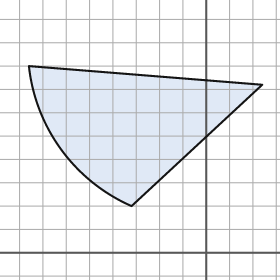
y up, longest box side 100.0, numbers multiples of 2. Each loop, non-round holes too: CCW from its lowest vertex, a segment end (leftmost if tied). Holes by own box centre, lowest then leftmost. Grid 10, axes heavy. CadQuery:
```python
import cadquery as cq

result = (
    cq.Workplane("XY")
    .moveTo(-32.0, 20.0)
    .lineTo(24.0, 72.0)
    .lineTo(-76.0, 80.0)
    .threePointArc((-62.0, 44.0), (-32.0, 20.0))
    .close()
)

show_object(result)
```